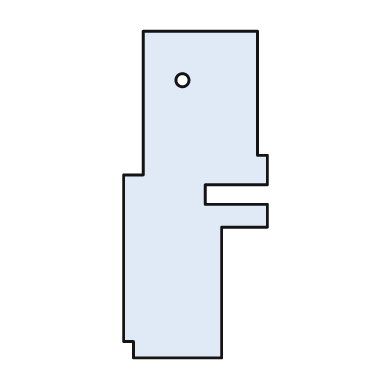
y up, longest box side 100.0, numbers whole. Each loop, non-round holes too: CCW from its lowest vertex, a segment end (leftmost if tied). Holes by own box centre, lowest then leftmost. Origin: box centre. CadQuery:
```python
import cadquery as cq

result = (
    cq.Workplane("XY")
    .moveTo(-19.0, -50.0)
    .lineTo(8.0, -50.0)
    .lineTo(8.0, -10.0)
    .lineTo(22.0, -10.0)
    .lineTo(22.0, -3.0)
    .lineTo(3.0, -3.0)
    .lineTo(3.0, 3.0)
    .lineTo(22.0, 3.0)
    .lineTo(22.0, 12.0)
    .lineTo(19.0, 12.0)
    .lineTo(19.0, 50.0)
    .lineTo(-16.0, 50.0)
    .lineTo(-16.0, 6.0)
    .lineTo(-22.0, 6.0)
    .lineTo(-22.0, -45.0)
    .lineTo(-19.0, -45.0)
    .close()
    .moveTo(-4.0, 35.0)
    .circle(2.0)
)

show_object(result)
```